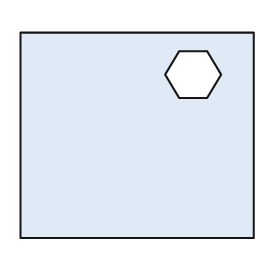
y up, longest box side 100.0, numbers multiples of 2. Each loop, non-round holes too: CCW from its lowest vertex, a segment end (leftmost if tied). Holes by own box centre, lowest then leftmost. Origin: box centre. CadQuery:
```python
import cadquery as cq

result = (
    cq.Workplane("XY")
    .moveTo(-50.0, -44.0)
    .lineTo(50.0, -44.0)
    .lineTo(50.0, 44.0)
    .lineTo(-50.0, 44.0)
    .close()
    .moveTo(18.0, 16.0)
    .lineTo(30.0, 16.0)
    .lineTo(36.0, 26.0)
    .lineTo(30.0, 36.0)
    .lineTo(18.0, 36.0)
    .lineTo(12.0, 26.0)
    .close()
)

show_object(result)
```